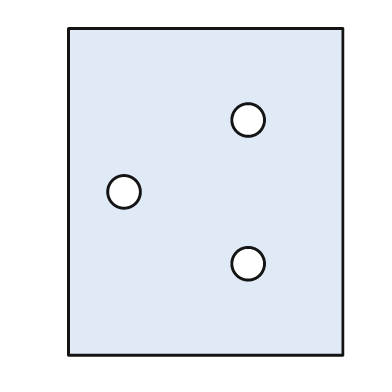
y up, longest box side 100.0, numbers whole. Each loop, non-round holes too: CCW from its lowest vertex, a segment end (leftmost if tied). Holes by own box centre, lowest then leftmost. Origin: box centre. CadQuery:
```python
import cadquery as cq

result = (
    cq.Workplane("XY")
    .moveTo(-42.0, -50.0)
    .lineTo(42.0, -50.0)
    .lineTo(42.0, 50.0)
    .lineTo(-42.0, 50.0)
    .close()
    .moveTo(13.0, -22.0)
    .circle(5.0)
    .moveTo(-25.0, 0.0)
    .circle(5.0)
    .moveTo(13.0, 22.0)
    .circle(5.0)
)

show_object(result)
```